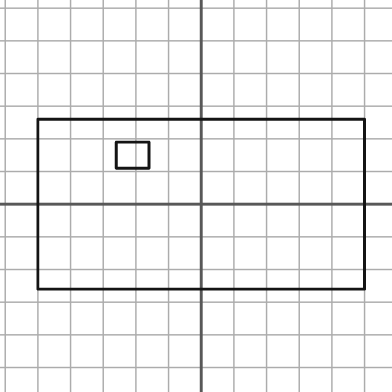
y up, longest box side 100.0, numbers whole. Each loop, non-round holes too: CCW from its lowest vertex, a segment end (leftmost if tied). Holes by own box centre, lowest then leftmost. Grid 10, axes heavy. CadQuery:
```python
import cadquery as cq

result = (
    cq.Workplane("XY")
    .moveTo(-50.0, -26.0)
    .lineTo(50.0, -26.0)
    .lineTo(50.0, 26.0)
    .lineTo(-50.0, 26.0)
    .close()
    .moveTo(-26.0, 11.0)
    .lineTo(-16.0, 11.0)
    .lineTo(-16.0, 19.0)
    .lineTo(-26.0, 19.0)
    .close()
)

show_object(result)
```